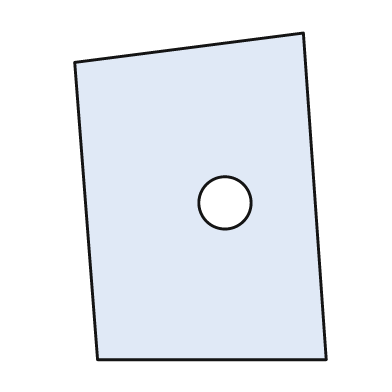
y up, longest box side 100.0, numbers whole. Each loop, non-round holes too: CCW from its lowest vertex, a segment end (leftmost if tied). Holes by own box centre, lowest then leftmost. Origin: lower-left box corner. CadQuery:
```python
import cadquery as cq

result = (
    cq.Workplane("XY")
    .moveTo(7.0, 0.0)
    .lineTo(77.0, 0.0)
    .lineTo(70.0, 100.0)
    .lineTo(0.0, 91.0)
    .close()
    .moveTo(46.0, 48.0)
    .circle(8.0)
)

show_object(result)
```